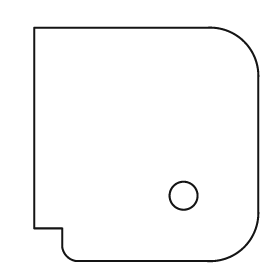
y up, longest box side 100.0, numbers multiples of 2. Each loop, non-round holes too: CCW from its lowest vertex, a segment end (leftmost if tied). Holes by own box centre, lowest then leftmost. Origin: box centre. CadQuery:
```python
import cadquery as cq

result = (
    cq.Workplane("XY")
    .moveTo(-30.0, -50.0)
    .lineTo(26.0, -50.0)
    .threePointArc((42.0, -44.0), (48.0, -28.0))
    .lineTo(48.0, 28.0)
    .threePointArc((42.0, 44.0), (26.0, 50.0))
    .lineTo(-48.0, 50.0)
    .lineTo(-48.0, -36.0)
    .lineTo(-36.0, -36.0)
    .lineTo(-36.0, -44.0)
    .threePointArc((-34.0, -48.0), (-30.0, -50.0))
    .close()
    .moveTo(16.0, -22.0)
    .circle(6.0)
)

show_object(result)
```